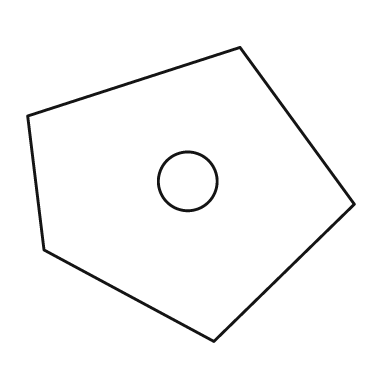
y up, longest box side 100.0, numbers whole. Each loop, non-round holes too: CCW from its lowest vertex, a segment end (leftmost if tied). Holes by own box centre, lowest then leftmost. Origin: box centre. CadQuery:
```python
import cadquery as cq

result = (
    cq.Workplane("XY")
    .moveTo(7.0, -45.0)
    .lineTo(50.0, -3.0)
    .lineTo(15.0, 45.0)
    .lineTo(-50.0, 24.0)
    .lineTo(-45.0, -17.0)
    .close()
    .moveTo(-1.0, 4.0)
    .circle(9.0)
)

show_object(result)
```